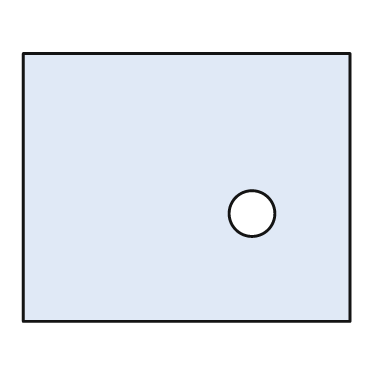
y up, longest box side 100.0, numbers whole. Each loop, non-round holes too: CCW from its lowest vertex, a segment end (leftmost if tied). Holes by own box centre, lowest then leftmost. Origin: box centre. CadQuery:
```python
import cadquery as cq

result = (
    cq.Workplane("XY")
    .moveTo(-50.0, -41.0)
    .lineTo(50.0, -41.0)
    .lineTo(50.0, 41.0)
    .lineTo(-50.0, 41.0)
    .close()
    .moveTo(20.0, -8.0)
    .circle(7.0)
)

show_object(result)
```